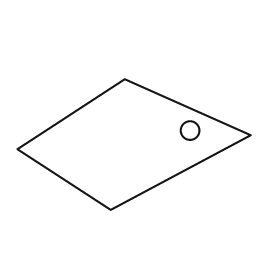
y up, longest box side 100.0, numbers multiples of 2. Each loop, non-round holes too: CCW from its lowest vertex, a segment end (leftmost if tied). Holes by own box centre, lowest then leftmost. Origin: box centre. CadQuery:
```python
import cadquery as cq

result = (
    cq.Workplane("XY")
    .moveTo(-10.0, -28.0)
    .lineTo(50.0, 4.0)
    .lineTo(-4.0, 28.0)
    .lineTo(-50.0, -2.0)
    .close()
    .moveTo(24.0, 6.0)
    .circle(4.0)
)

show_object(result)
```